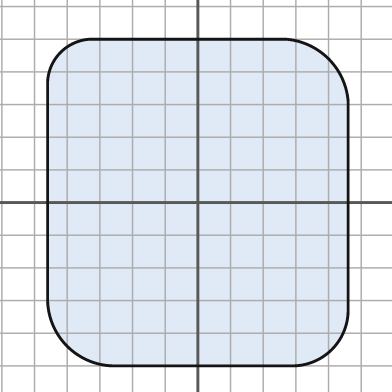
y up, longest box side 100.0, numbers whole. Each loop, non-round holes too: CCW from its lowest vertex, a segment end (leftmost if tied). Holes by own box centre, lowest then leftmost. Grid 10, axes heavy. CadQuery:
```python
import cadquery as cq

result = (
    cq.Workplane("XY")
    .moveTo(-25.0, -50.0)
    .lineTo(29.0, -50.0)
    .threePointArc((41.0, -45.0), (46.0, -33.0))
    .lineTo(46.0, 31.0)
    .threePointArc((40.0, 44.0), (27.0, 50.0))
    .lineTo(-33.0, 50.0)
    .threePointArc((-42.0, 46.0), (-46.0, 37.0))
    .lineTo(-46.0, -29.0)
    .threePointArc((-40.0, -44.0), (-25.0, -50.0))
    .close()
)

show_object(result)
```